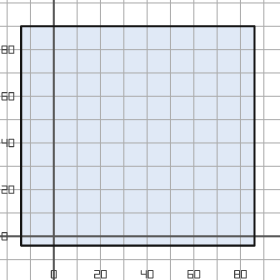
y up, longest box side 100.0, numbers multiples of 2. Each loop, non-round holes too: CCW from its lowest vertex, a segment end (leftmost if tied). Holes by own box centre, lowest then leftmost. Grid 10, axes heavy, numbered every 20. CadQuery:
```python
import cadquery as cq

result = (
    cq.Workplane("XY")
    .moveTo(-14.0, -4.0)
    .lineTo(86.0, -4.0)
    .lineTo(86.0, 90.0)
    .lineTo(-14.0, 90.0)
    .close()
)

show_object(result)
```